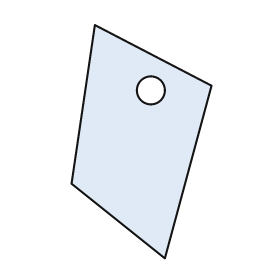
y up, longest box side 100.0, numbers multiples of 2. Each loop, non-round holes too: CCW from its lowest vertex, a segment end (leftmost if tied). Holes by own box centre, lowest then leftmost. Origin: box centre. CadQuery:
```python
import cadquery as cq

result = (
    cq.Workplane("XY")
    .moveTo(10.0, -50.0)
    .lineTo(30.0, 24.0)
    .lineTo(-20.0, 50.0)
    .lineTo(-30.0, -18.0)
    .close()
    .moveTo(4.0, 22.0)
    .circle(6.0)
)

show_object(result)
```